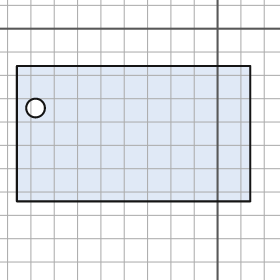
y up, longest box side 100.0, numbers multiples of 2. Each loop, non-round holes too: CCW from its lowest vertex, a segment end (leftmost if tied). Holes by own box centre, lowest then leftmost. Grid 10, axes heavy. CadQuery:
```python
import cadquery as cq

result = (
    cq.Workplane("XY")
    .moveTo(-86.0, -74.0)
    .lineTo(14.0, -74.0)
    .lineTo(14.0, -16.0)
    .lineTo(-86.0, -16.0)
    .close()
    .moveTo(-78.0, -34.0)
    .circle(4.0)
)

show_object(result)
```